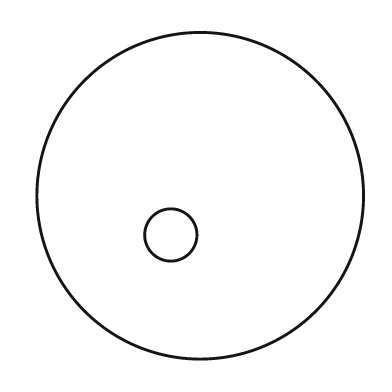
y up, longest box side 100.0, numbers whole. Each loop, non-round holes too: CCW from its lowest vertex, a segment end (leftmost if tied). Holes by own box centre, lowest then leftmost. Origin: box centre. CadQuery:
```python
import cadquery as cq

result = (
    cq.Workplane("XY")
    .moveTo(0.0, 0.0)
    .circle(50.0)
    .moveTo(-9.0, -12.0)
    .circle(8.0)
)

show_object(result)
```